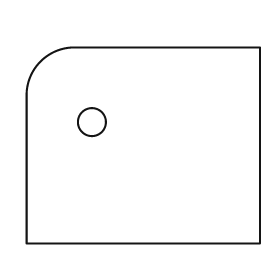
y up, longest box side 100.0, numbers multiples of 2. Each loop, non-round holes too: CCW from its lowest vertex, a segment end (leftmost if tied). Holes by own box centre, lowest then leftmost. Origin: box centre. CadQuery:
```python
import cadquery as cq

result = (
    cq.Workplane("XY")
    .moveTo(-50.0, -42.0)
    .lineTo(50.0, -42.0)
    .lineTo(50.0, 42.0)
    .lineTo(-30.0, 42.0)
    .threePointArc((-44.0, 36.0), (-50.0, 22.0))
    .close()
    .moveTo(-22.0, 10.0)
    .circle(6.0)
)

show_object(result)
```